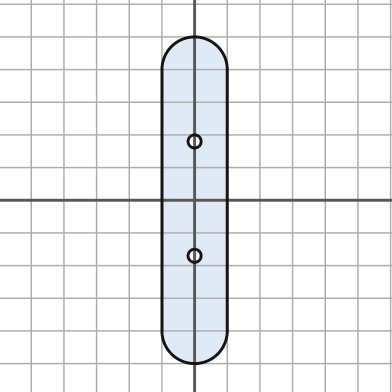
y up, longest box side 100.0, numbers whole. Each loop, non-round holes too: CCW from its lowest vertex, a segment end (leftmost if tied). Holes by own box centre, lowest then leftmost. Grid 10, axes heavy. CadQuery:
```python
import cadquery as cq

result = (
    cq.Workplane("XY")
    .moveTo(-10.0, -40.0)
    .threePointArc((0.0, -50.0), (10.0, -40.0))
    .lineTo(10.0, 40.0)
    .threePointArc((0.0, 50.0), (-10.0, 40.0))
    .close()
    .moveTo(0.0, -17.0)
    .circle(2.0)
    .moveTo(0.0, 18.0)
    .circle(2.0)
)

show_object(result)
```